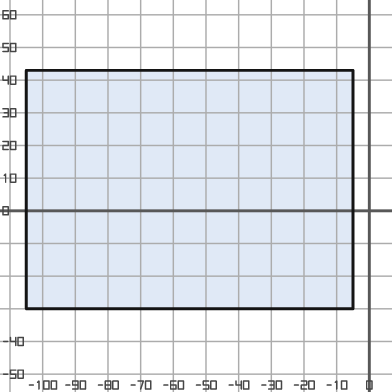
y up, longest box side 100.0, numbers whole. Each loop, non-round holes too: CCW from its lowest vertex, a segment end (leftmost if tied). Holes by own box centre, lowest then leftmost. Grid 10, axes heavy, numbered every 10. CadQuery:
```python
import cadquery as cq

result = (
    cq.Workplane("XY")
    .moveTo(-105.0, -30.0)
    .lineTo(-5.0, -30.0)
    .lineTo(-5.0, 43.0)
    .lineTo(-105.0, 43.0)
    .close()
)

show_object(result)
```